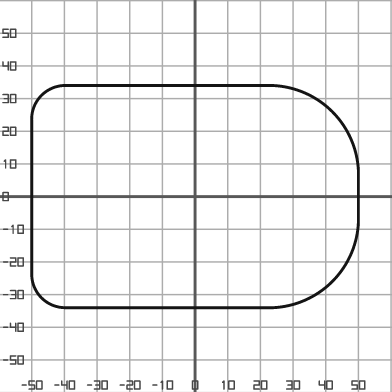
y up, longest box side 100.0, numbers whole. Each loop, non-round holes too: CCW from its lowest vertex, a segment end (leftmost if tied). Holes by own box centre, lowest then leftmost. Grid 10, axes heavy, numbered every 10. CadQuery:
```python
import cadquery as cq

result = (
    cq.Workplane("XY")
    .moveTo(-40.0, -34.0)
    .lineTo(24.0, -34.0)
    .threePointArc((42.0, -26.0), (50.0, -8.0))
    .lineTo(50.0, 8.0)
    .threePointArc((42.0, 26.0), (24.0, 34.0))
    .lineTo(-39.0, 34.0)
    .threePointArc((-47.0, 31.0), (-50.0, 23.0))
    .lineTo(-50.0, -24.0)
    .threePointArc((-47.0, -31.0), (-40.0, -34.0))
    .close()
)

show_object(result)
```